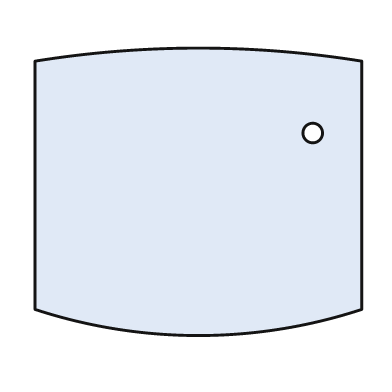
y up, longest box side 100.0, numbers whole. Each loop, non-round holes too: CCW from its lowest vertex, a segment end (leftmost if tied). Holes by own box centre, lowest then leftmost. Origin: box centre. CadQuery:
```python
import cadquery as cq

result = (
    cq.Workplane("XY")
    .moveTo(-50.0, -36.0)
    .threePointArc((0.0, -44.0), (50.0, -36.0))
    .lineTo(50.0, 40.0)
    .threePointArc((0.0, 44.0), (-50.0, 40.0))
    .close()
    .moveTo(35.0, 18.0)
    .circle(3.0)
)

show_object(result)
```